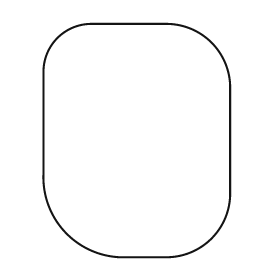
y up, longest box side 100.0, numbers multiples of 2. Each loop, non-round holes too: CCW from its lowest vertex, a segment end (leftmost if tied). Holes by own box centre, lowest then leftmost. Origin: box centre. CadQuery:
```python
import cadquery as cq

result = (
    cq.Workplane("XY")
    .moveTo(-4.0, -50.0)
    .lineTo(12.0, -50.0)
    .threePointArc((32.0, -42.0), (40.0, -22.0))
    .lineTo(40.0, 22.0)
    .threePointArc((32.0, 42.0), (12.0, 50.0))
    .lineTo(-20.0, 50.0)
    .threePointArc((-34.0, 44.0), (-40.0, 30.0))
    .lineTo(-40.0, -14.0)
    .threePointArc((-30.0, -40.0), (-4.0, -50.0))
    .close()
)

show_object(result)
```